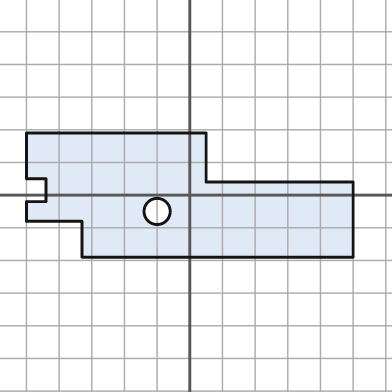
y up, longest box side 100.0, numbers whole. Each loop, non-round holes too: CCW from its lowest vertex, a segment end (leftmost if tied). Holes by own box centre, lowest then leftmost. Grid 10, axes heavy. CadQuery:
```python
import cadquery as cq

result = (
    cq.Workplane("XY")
    .moveTo(-33.0, -19.0)
    .lineTo(50.0, -19.0)
    .lineTo(50.0, 4.0)
    .lineTo(5.0, 4.0)
    .lineTo(5.0, 19.0)
    .lineTo(-50.0, 19.0)
    .lineTo(-50.0, 5.0)
    .lineTo(-44.0, 5.0)
    .lineTo(-44.0, -2.0)
    .lineTo(-50.0, -2.0)
    .lineTo(-50.0, -8.0)
    .lineTo(-33.0, -8.0)
    .close()
    .moveTo(-10.0, -5.0)
    .circle(4.0)
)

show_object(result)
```